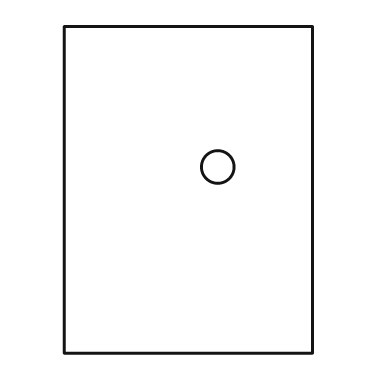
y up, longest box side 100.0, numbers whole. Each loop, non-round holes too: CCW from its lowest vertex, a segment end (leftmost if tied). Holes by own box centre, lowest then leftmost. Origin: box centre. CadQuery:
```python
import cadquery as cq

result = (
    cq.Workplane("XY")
    .moveTo(-38.0, -50.0)
    .lineTo(38.0, -50.0)
    .lineTo(38.0, 50.0)
    .lineTo(-38.0, 50.0)
    .close()
    .moveTo(9.0, 7.0)
    .circle(5.0)
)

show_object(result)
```